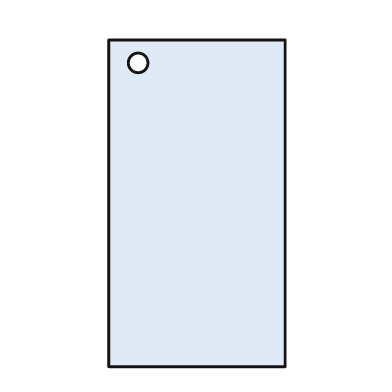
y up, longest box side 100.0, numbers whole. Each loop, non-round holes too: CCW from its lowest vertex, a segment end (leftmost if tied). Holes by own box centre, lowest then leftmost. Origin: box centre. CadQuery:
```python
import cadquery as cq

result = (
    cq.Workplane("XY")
    .moveTo(-27.0, -50.0)
    .lineTo(27.0, -50.0)
    .lineTo(27.0, 50.0)
    .lineTo(-27.0, 50.0)
    .close()
    .moveTo(-18.0, 43.0)
    .circle(3.0)
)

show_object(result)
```